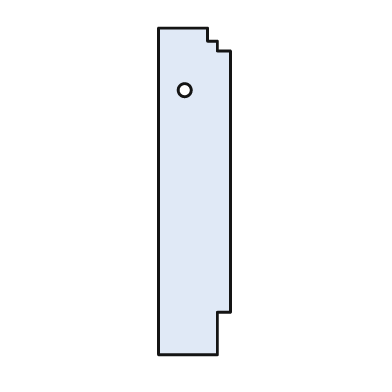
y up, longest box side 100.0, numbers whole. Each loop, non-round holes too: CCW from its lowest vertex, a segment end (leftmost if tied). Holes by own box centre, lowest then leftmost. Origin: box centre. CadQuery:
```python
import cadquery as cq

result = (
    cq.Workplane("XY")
    .moveTo(-11.0, -50.0)
    .lineTo(7.0, -50.0)
    .lineTo(7.0, -37.0)
    .lineTo(11.0, -37.0)
    .lineTo(11.0, 43.0)
    .lineTo(7.0, 43.0)
    .lineTo(7.0, 46.0)
    .lineTo(4.0, 46.0)
    .lineTo(4.0, 50.0)
    .lineTo(-11.0, 50.0)
    .close()
    .moveTo(-3.0, 31.0)
    .circle(2.0)
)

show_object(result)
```